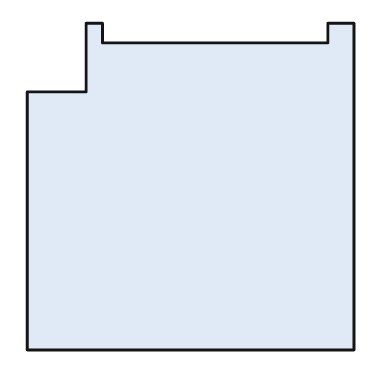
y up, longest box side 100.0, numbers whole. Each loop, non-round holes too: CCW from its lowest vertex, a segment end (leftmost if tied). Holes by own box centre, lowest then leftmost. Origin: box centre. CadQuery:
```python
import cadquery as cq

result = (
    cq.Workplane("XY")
    .moveTo(-50.0, -50.0)
    .lineTo(50.0, -50.0)
    .lineTo(50.0, 50.0)
    .lineTo(42.0, 50.0)
    .lineTo(42.0, 44.0)
    .lineTo(-27.0, 44.0)
    .lineTo(-27.0, 50.0)
    .lineTo(-32.0, 50.0)
    .lineTo(-32.0, 29.0)
    .lineTo(-50.0, 29.0)
    .close()
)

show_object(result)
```